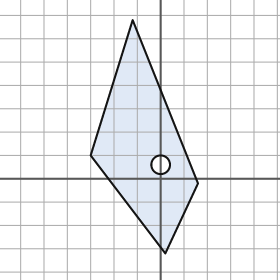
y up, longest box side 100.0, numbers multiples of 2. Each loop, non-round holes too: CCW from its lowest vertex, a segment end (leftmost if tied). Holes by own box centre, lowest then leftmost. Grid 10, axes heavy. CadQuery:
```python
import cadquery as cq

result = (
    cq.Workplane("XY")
    .moveTo(2.0, -32.0)
    .lineTo(16.0, -2.0)
    .lineTo(-12.0, 68.0)
    .lineTo(-30.0, 10.0)
    .close()
    .moveTo(0.0, 6.0)
    .circle(4.0)
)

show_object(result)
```